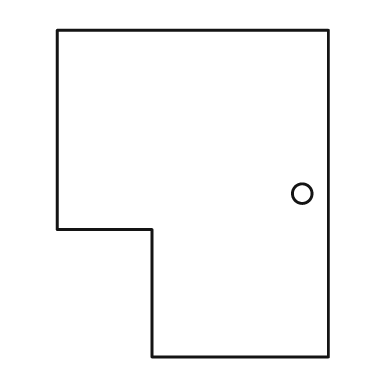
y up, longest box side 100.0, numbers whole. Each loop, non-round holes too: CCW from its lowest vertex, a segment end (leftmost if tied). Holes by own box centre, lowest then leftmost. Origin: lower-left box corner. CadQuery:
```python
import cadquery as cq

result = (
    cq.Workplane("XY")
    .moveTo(29.0, 0.0)
    .lineTo(83.0, 0.0)
    .lineTo(83.0, 100.0)
    .lineTo(0.0, 100.0)
    .lineTo(0.0, 39.0)
    .lineTo(29.0, 39.0)
    .close()
    .moveTo(75.0, 50.0)
    .circle(3.0)
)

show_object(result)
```